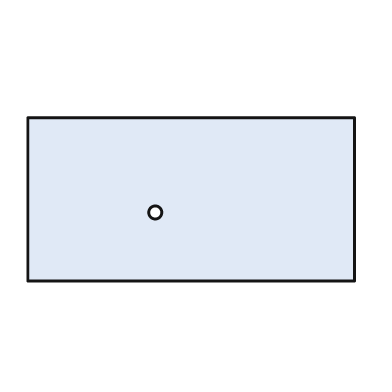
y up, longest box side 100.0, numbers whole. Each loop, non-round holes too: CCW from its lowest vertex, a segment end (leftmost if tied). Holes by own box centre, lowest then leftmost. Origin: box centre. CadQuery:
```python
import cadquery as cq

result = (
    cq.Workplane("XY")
    .moveTo(-50.0, -25.0)
    .lineTo(50.0, -25.0)
    .lineTo(50.0, 25.0)
    .lineTo(-50.0, 25.0)
    .close()
    .moveTo(-11.0, -4.0)
    .circle(2.0)
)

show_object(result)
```